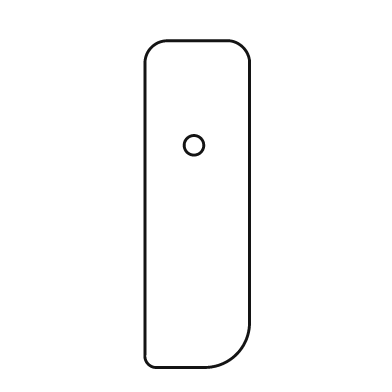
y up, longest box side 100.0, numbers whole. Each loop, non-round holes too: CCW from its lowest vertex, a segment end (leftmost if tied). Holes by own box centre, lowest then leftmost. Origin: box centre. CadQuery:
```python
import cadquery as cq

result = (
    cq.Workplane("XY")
    .moveTo(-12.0, -50.0)
    .lineTo(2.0, -50.0)
    .threePointArc((12.0, -46.0), (16.0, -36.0))
    .lineTo(16.0, 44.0)
    .threePointArc((14.0, 48.0), (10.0, 50.0))
    .lineTo(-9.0, 50.0)
    .threePointArc((-14.0, 48.0), (-16.0, 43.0))
    .lineTo(-16.0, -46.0)
    .threePointArc((-15.0, -49.0), (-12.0, -50.0))
    .close()
    .moveTo(-1.0, 18.0)
    .circle(3.0)
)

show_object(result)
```